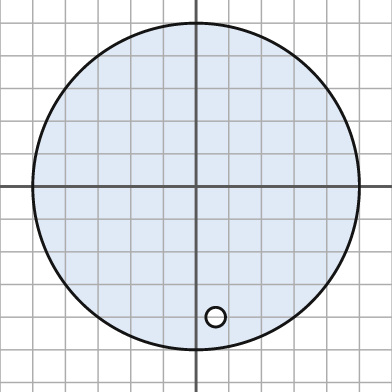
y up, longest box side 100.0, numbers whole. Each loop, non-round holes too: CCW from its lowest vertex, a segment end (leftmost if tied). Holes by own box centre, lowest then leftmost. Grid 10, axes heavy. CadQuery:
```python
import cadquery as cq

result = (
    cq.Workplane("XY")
    .moveTo(0.0, 0.0)
    .circle(50.0)
    .moveTo(6.0, -40.0)
    .circle(3.0)
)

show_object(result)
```